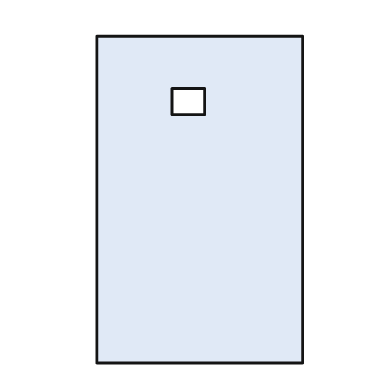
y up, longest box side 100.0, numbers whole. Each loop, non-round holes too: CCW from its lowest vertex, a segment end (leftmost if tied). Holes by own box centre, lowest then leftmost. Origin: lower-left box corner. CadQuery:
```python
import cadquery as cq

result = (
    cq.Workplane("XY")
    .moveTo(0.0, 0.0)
    .lineTo(63.0, 0.0)
    .lineTo(63.0, 100.0)
    .lineTo(0.0, 100.0)
    .close()
    .moveTo(23.0, 76.0)
    .lineTo(33.0, 76.0)
    .lineTo(33.0, 84.0)
    .lineTo(23.0, 84.0)
    .close()
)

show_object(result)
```